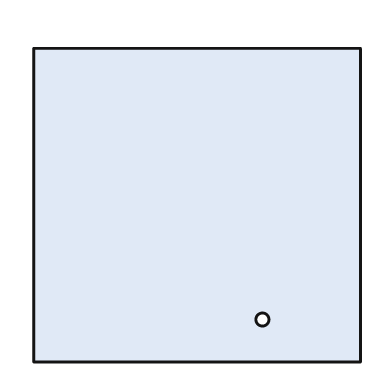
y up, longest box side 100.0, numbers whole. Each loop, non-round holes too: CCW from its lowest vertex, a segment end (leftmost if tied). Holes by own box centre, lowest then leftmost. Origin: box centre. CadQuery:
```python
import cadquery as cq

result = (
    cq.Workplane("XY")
    .moveTo(-50.0, -48.0)
    .lineTo(50.0, -48.0)
    .lineTo(50.0, 48.0)
    .lineTo(-50.0, 48.0)
    .close()
    .moveTo(20.0, -35.0)
    .circle(2.0)
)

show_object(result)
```